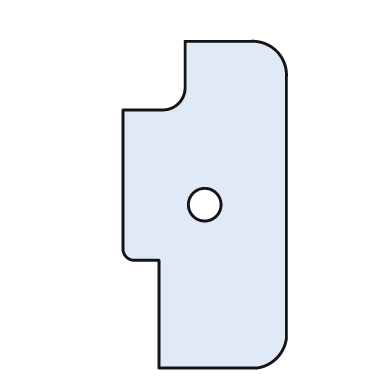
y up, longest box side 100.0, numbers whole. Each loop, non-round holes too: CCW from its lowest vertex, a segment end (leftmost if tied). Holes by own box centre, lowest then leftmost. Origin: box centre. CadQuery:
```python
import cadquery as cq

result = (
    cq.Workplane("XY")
    .moveTo(-14.0, -50.0)
    .lineTo(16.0, -50.0)
    .threePointArc((22.0, -47.0), (25.0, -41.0))
    .lineTo(25.0, 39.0)
    .threePointArc((22.0, 47.0), (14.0, 50.0))
    .lineTo(-6.0, 50.0)
    .lineTo(-6.0, 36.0)
    .threePointArc((-8.0, 31.0), (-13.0, 29.0))
    .lineTo(-25.0, 29.0)
    .lineTo(-25.0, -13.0)
    .threePointArc((-24.0, -16.0), (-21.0, -17.0))
    .lineTo(-14.0, -17.0)
    .close()
    .moveTo(0.0, 0.0)
    .circle(5.0)
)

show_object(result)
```